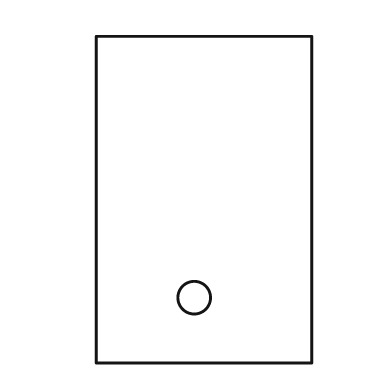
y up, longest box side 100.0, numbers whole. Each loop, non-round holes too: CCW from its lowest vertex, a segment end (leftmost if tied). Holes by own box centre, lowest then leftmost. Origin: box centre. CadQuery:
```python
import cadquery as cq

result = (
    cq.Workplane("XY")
    .moveTo(-33.0, -50.0)
    .lineTo(33.0, -50.0)
    .lineTo(33.0, 50.0)
    .lineTo(-33.0, 50.0)
    .close()
    .moveTo(-3.0, -30.0)
    .circle(5.0)
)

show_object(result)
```